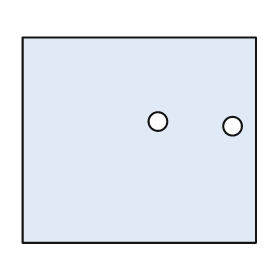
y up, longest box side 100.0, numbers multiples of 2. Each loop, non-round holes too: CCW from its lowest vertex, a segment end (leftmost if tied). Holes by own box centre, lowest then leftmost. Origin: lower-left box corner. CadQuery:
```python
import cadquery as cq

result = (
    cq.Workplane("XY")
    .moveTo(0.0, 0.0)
    .lineTo(100.0, 0.0)
    .lineTo(100.0, 88.0)
    .lineTo(0.0, 88.0)
    .close()
    .moveTo(90.0, 50.0)
    .circle(4.0)
    .moveTo(58.0, 52.0)
    .circle(4.0)
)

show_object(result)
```